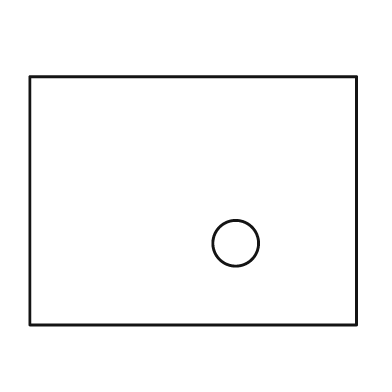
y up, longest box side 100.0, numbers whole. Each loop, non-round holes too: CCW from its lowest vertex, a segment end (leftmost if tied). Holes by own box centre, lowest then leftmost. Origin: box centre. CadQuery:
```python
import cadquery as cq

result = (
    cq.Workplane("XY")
    .moveTo(-50.0, -38.0)
    .lineTo(50.0, -38.0)
    .lineTo(50.0, 38.0)
    .lineTo(-50.0, 38.0)
    .close()
    .moveTo(13.0, -13.0)
    .circle(7.0)
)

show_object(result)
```